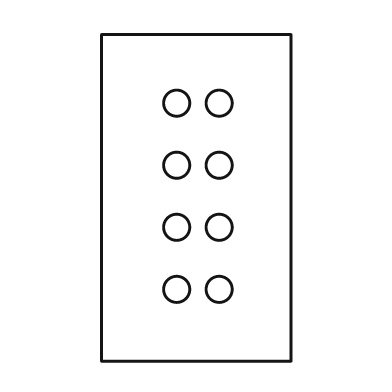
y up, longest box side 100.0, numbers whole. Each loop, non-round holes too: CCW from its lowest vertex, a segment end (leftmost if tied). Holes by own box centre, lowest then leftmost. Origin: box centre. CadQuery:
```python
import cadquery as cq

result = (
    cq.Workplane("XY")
    .moveTo(-29.0, -50.0)
    .lineTo(29.0, -50.0)
    .lineTo(29.0, 50.0)
    .lineTo(-29.0, 50.0)
    .close()
    .moveTo(-6.0, -28.0)
    .circle(4.0)
    .moveTo(7.0, -28.0)
    .circle(4.0)
    .moveTo(-6.0, -9.0)
    .circle(4.0)
    .moveTo(7.0, -9.0)
    .circle(4.0)
    .moveTo(-6.0, 10.0)
    .circle(4.0)
    .moveTo(7.0, 10.0)
    .circle(4.0)
    .moveTo(-6.0, 29.0)
    .circle(4.0)
    .moveTo(7.0, 29.0)
    .circle(4.0)
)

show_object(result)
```